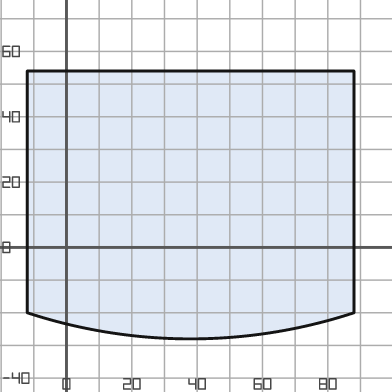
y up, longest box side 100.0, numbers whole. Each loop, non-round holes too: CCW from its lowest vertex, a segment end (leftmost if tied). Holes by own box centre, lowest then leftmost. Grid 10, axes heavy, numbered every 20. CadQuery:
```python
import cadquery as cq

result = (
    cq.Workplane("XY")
    .moveTo(-12.0, -20.0)
    .threePointArc((38.0, -28.0), (88.0, -20.0))
    .lineTo(88.0, 54.0)
    .lineTo(-12.0, 54.0)
    .close()
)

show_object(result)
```